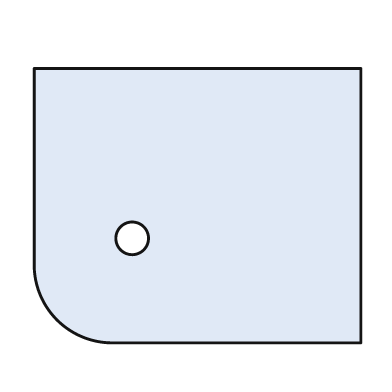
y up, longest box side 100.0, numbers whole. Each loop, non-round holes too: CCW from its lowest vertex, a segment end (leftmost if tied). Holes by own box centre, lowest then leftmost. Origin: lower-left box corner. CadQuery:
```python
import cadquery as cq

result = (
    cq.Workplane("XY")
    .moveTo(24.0, 0.0)
    .lineTo(100.0, 0.0)
    .lineTo(100.0, 84.0)
    .lineTo(0.0, 84.0)
    .lineTo(0.0, 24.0)
    .threePointArc((7.0, 7.0), (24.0, 0.0))
    .close()
    .moveTo(30.0, 32.0)
    .circle(5.0)
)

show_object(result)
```